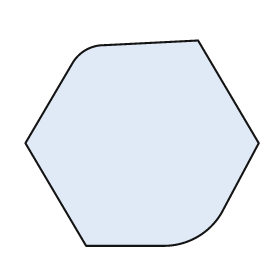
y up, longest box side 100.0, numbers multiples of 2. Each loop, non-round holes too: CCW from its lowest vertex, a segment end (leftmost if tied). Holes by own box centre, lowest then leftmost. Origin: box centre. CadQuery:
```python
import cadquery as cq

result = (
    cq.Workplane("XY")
    .moveTo(-24.0, -44.0)
    .lineTo(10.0, -44.0)
    .threePointArc((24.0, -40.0), (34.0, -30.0))
    .lineTo(50.0, 0.0)
    .lineTo(24.0, 44.0)
    .lineTo(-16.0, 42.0)
    .threePointArc((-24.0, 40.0), (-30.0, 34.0))
    .lineTo(-50.0, 0.0)
    .close()
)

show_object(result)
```